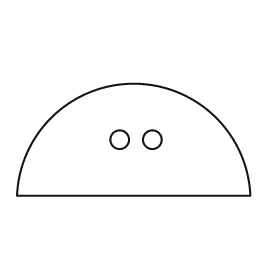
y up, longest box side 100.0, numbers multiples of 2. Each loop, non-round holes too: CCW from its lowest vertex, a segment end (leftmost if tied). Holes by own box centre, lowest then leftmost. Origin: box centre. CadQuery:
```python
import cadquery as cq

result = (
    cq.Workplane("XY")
    .moveTo(-50.0, -24.0)
    .lineTo(50.0, -24.0)
    .threePointArc((0.0, 24.0), (-50.0, -24.0))
    .close()
    .moveTo(-6.0, 0.0)
    .circle(4.0)
    .moveTo(8.0, 0.0)
    .circle(4.0)
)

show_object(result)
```